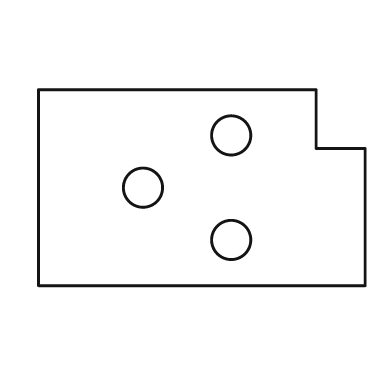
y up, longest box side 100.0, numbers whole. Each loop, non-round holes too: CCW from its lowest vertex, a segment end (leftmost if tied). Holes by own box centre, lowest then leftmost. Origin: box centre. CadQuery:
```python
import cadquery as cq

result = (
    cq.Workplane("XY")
    .moveTo(-50.0, -30.0)
    .lineTo(50.0, -30.0)
    .lineTo(50.0, 12.0)
    .lineTo(35.0, 12.0)
    .lineTo(35.0, 30.0)
    .lineTo(-50.0, 30.0)
    .close()
    .moveTo(9.0, -16.0)
    .circle(6.0)
    .moveTo(-18.0, 0.0)
    .circle(6.0)
    .moveTo(9.0, 16.0)
    .circle(6.0)
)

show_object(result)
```